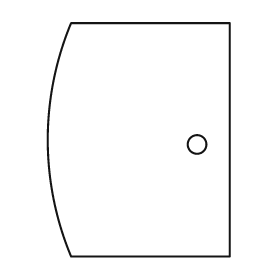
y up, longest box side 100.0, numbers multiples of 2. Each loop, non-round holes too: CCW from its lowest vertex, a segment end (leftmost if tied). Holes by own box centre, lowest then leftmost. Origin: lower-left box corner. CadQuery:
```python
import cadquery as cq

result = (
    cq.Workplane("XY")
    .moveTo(10.0, 0.0)
    .lineTo(78.0, 0.0)
    .lineTo(78.0, 100.0)
    .lineTo(10.0, 100.0)
    .threePointArc((0.0, 50.0), (10.0, 0.0))
    .close()
    .moveTo(64.0, 48.0)
    .circle(4.0)
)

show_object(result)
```